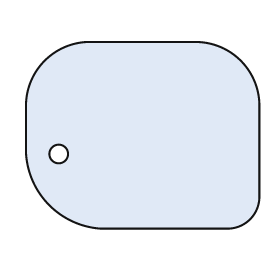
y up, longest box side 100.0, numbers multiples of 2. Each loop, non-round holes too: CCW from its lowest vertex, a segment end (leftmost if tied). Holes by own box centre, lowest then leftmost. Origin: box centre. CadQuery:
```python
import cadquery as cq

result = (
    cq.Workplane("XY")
    .moveTo(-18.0, -40.0)
    .lineTo(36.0, -40.0)
    .threePointArc((46.0, -36.0), (50.0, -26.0))
    .lineTo(50.0, 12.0)
    .threePointArc((42.0, 32.0), (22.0, 40.0))
    .lineTo(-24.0, 40.0)
    .threePointArc((-42.0, 32.0), (-50.0, 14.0))
    .lineTo(-50.0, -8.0)
    .threePointArc((-40.0, -30.0), (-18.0, -40.0))
    .close()
    .moveTo(-36.0, -8.0)
    .circle(4.0)
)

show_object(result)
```